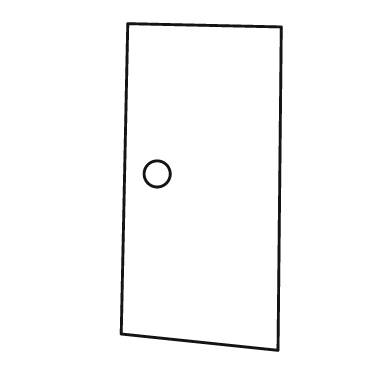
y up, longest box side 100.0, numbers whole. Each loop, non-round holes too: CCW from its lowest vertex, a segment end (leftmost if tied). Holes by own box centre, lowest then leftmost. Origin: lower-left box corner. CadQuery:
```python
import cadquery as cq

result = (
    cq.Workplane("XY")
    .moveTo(48.0, 0.0)
    .lineTo(49.0, 99.0)
    .lineTo(2.0, 100.0)
    .lineTo(0.0, 5.0)
    .close()
    .moveTo(11.0, 54.0)
    .circle(4.0)
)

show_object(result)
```